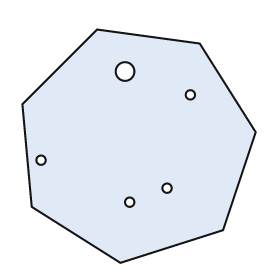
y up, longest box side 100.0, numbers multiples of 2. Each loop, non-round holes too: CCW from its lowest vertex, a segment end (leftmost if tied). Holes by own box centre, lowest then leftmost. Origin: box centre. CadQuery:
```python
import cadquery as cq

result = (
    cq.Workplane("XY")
    .moveTo(-8.0, -50.0)
    .lineTo(36.0, -36.0)
    .lineTo(50.0, 6.0)
    .lineTo(26.0, 44.0)
    .lineTo(-18.0, 50.0)
    .lineTo(-50.0, 18.0)
    .lineTo(-46.0, -26.0)
    .close()
    .moveTo(-4.0, -24.0)
    .circle(2.0)
    .moveTo(12.0, -18.0)
    .circle(2.0)
    .moveTo(-42.0, -6.0)
    .circle(2.0)
    .moveTo(22.0, 22.0)
    .circle(2.0)
    .moveTo(-6.0, 32.0)
    .circle(4.0)
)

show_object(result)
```